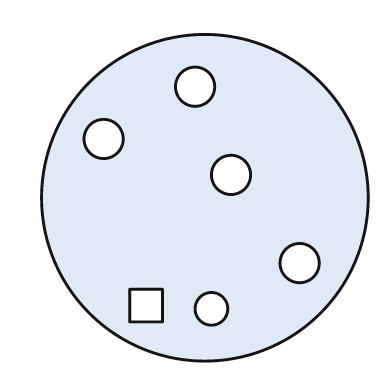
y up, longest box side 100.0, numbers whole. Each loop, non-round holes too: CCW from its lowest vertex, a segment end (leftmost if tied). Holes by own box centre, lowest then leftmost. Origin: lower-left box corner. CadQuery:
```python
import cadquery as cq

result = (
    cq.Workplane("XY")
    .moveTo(50.0, 50.0)
    .circle(50.0)
    .moveTo(52.0, 16.0)
    .circle(5.0)
    .moveTo(27.0, 12.0)
    .lineTo(37.0, 12.0)
    .lineTo(37.0, 22.0)
    .lineTo(27.0, 22.0)
    .close()
    .moveTo(79.0, 30.0)
    .circle(6.0)
    .moveTo(58.0, 57.0)
    .circle(6.0)
    .moveTo(19.0, 68.0)
    .circle(6.0)
    .moveTo(47.0, 84.0)
    .circle(6.0)
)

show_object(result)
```